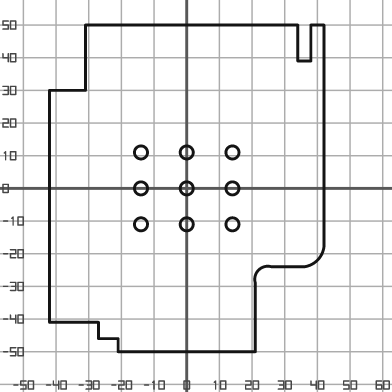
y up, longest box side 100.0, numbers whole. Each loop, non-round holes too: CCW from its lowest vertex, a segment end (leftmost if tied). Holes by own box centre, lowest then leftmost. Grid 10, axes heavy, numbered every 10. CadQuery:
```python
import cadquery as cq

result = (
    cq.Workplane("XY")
    .moveTo(-21.0, -50.0)
    .lineTo(21.0, -50.0)
    .lineTo(21.0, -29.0)
    .threePointArc((22.0, -25.0), (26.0, -24.0))
    .lineTo(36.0, -24.0)
    .threePointArc((40.0, -22.0), (42.0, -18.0))
    .lineTo(42.0, 50.0)
    .lineTo(38.0, 50.0)
    .lineTo(38.0, 39.0)
    .lineTo(34.0, 39.0)
    .lineTo(34.0, 50.0)
    .lineTo(-31.0, 50.0)
    .lineTo(-31.0, 30.0)
    .lineTo(-42.0, 30.0)
    .lineTo(-42.0, -41.0)
    .lineTo(-27.0, -41.0)
    .lineTo(-27.0, -46.0)
    .lineTo(-21.0, -46.0)
    .close()
    .moveTo(-14.0, -11.0)
    .circle(2.0)
    .moveTo(0.0, -11.0)
    .circle(2.0)
    .moveTo(14.0, -11.0)
    .circle(2.0)
    .moveTo(-14.0, 0.0)
    .circle(2.0)
    .moveTo(0.0, 0.0)
    .circle(2.0)
    .moveTo(14.0, 0.0)
    .circle(2.0)
    .moveTo(-14.0, 11.0)
    .circle(2.0)
    .moveTo(0.0, 11.0)
    .circle(2.0)
    .moveTo(14.0, 11.0)
    .circle(2.0)
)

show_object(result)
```